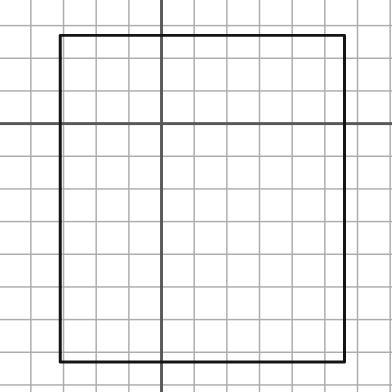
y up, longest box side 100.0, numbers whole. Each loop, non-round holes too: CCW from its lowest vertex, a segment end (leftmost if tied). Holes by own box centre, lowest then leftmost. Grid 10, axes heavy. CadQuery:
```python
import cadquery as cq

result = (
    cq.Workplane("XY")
    .moveTo(-31.0, -73.0)
    .lineTo(56.0, -73.0)
    .lineTo(56.0, 27.0)
    .lineTo(-31.0, 27.0)
    .close()
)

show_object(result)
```